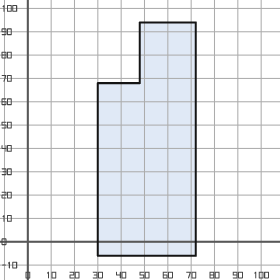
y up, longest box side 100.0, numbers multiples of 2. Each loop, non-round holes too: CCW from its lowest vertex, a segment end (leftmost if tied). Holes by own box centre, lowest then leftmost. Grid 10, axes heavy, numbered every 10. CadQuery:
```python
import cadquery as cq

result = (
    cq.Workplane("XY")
    .moveTo(30.0, -6.0)
    .lineTo(72.0, -6.0)
    .lineTo(72.0, 94.0)
    .lineTo(48.0, 94.0)
    .lineTo(48.0, 68.0)
    .lineTo(30.0, 68.0)
    .close()
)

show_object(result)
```